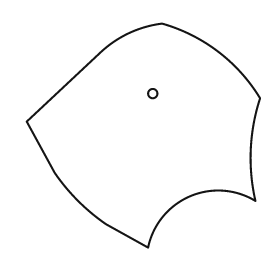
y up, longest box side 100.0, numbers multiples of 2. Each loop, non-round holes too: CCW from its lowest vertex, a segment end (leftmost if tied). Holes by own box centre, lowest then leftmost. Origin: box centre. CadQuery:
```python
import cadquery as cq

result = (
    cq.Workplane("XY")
    .moveTo(2.0, -48.0)
    .threePointArc((20.0, -26.0), (48.0, -28.0))
    .threePointArc((46.0, -6.0), (50.0, 16.0))
    .threePointArc((32.0, 36.0), (8.0, 48.0))
    .threePointArc((-6.0, 44.0), (-18.0, 36.0))
    .lineTo(-50.0, 6.0)
    .lineTo(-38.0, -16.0)
    .threePointArc((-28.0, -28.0), (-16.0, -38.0))
    .close()
    .moveTo(4.0, 18.0)
    .circle(2.0)
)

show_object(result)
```